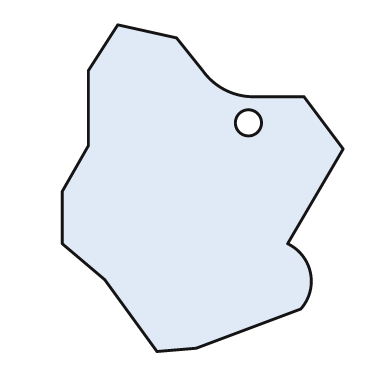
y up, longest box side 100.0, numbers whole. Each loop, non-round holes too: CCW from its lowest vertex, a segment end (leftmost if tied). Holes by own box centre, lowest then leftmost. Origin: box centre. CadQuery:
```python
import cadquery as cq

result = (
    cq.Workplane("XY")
    .moveTo(-14.0, -50.0)
    .lineTo(-2.0, -49.0)
    .lineTo(30.0, -37.0)
    .threePointArc((33.0, -26.0), (26.0, -17.0))
    .lineTo(43.0, 12.0)
    .lineTo(31.0, 28.0)
    .lineTo(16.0, 28.0)
    .threePointArc((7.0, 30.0), (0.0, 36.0))
    .lineTo(-8.0, 46.0)
    .lineTo(-26.0, 50.0)
    .lineTo(-35.0, 36.0)
    .lineTo(-35.0, 13.0)
    .lineTo(-43.0, -1.0)
    .lineTo(-43.0, -17.0)
    .lineTo(-30.0, -28.0)
    .close()
    .moveTo(14.0, 20.0)
    .circle(4.0)
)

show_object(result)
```